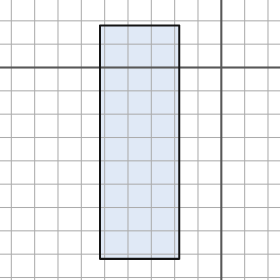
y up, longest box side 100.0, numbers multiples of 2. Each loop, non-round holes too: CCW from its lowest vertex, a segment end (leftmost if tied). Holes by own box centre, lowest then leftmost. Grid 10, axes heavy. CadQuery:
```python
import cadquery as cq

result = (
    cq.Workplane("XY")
    .moveTo(-52.0, -82.0)
    .lineTo(-18.0, -82.0)
    .lineTo(-18.0, 18.0)
    .lineTo(-52.0, 18.0)
    .close()
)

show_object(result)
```